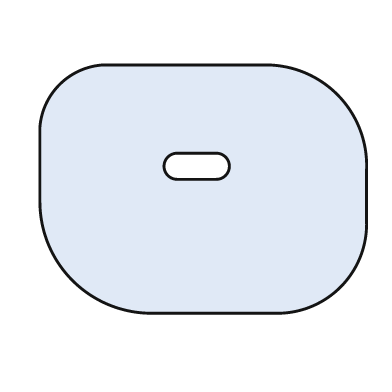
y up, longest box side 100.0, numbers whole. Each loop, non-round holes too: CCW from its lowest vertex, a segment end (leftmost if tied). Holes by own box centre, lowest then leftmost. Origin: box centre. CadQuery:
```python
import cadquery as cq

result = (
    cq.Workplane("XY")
    .moveTo(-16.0, -38.0)
    .lineTo(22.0, -38.0)
    .threePointArc((42.0, -30.0), (50.0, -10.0))
    .lineTo(50.0, 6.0)
    .threePointArc((41.0, 29.0), (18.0, 38.0))
    .lineTo(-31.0, 38.0)
    .threePointArc((-44.0, 32.0), (-50.0, 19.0))
    .lineTo(-50.0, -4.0)
    .threePointArc((-40.0, -28.0), (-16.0, -38.0))
    .close()
    .moveTo(-8.0, 3.0)
    .lineTo(4.0, 3.0)
    .threePointArc((8.0, 7.0), (4.0, 11.0))
    .lineTo(-8.0, 11.0)
    .threePointArc((-12.0, 7.0), (-8.0, 3.0))
    .close()
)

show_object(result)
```